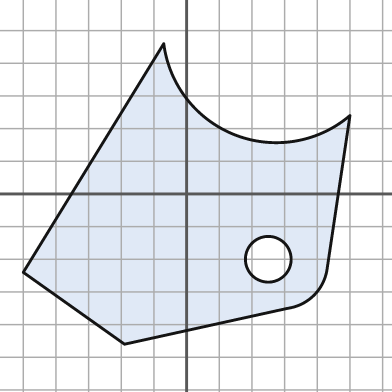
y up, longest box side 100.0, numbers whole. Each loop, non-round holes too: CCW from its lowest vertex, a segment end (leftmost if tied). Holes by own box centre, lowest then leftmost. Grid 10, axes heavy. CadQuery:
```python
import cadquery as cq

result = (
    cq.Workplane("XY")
    .moveTo(-19.0, -46.0)
    .lineTo(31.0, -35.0)
    .threePointArc((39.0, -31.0), (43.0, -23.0))
    .lineTo(50.0, 24.0)
    .threePointArc((15.0, 18.0), (-7.0, 46.0))
    .lineTo(-50.0, -24.0)
    .close()
    .moveTo(25.0, -20.0)
    .circle(7.0)
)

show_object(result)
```